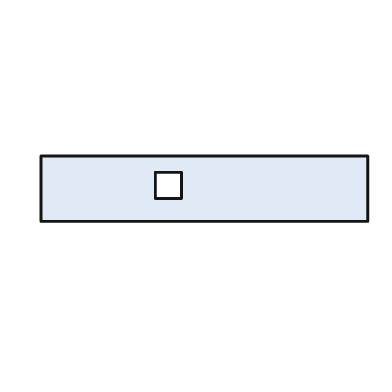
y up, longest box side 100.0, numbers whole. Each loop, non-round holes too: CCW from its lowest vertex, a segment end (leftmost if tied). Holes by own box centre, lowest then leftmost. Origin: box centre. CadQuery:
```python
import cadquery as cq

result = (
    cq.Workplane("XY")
    .moveTo(-50.0, -10.0)
    .lineTo(50.0, -10.0)
    .lineTo(50.0, 10.0)
    .lineTo(-50.0, 10.0)
    .close()
    .moveTo(-15.0, -3.0)
    .lineTo(-7.0, -3.0)
    .lineTo(-7.0, 5.0)
    .lineTo(-15.0, 5.0)
    .close()
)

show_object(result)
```